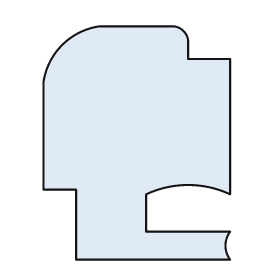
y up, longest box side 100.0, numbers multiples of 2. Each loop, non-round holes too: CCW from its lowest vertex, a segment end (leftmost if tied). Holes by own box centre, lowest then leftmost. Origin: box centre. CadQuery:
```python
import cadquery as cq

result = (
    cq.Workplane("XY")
    .moveTo(-26.0, -50.0)
    .lineTo(40.0, -50.0)
    .threePointArc((38.0, -44.0), (40.0, -38.0))
    .lineTo(4.0, -38.0)
    .lineTo(4.0, -22.0)
    .threePointArc((22.0, -18.0), (40.0, -22.0))
    .lineTo(40.0, 36.0)
    .lineTo(22.0, 36.0)
    .lineTo(22.0, 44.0)
    .threePointArc((20.0, 48.0), (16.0, 50.0))
    .lineTo(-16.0, 50.0)
    .threePointArc((-32.0, 42.0), (-40.0, 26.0))
    .lineTo(-40.0, -20.0)
    .lineTo(-26.0, -20.0)
    .close()
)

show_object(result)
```